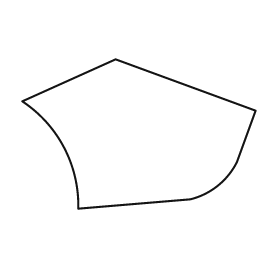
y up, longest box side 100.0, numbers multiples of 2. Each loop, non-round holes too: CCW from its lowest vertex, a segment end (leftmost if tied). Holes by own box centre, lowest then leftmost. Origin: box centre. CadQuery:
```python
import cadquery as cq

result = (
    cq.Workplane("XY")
    .moveTo(-26.0, -32.0)
    .lineTo(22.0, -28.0)
    .threePointArc((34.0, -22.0), (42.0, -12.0))
    .lineTo(50.0, 10.0)
    .lineTo(-10.0, 32.0)
    .lineTo(-50.0, 14.0)
    .threePointArc((-32.0, -6.0), (-26.0, -32.0))
    .close()
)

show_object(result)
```